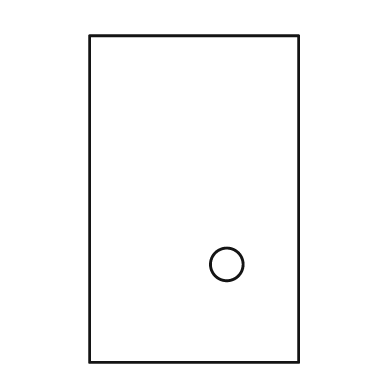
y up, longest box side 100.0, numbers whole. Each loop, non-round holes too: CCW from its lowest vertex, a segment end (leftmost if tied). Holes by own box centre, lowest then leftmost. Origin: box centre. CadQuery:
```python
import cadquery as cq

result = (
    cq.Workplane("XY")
    .moveTo(-32.0, -50.0)
    .lineTo(32.0, -50.0)
    .lineTo(32.0, 50.0)
    .lineTo(-32.0, 50.0)
    .close()
    .moveTo(10.0, -20.0)
    .circle(5.0)
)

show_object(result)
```